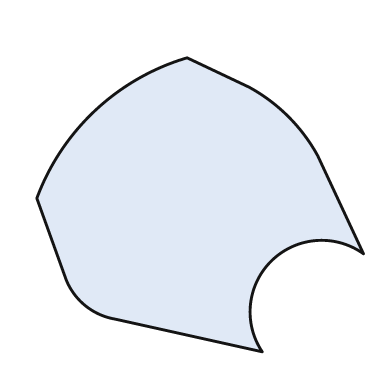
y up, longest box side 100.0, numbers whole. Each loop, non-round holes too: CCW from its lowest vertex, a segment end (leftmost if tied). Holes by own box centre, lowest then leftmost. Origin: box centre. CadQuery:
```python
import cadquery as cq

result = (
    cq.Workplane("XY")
    .moveTo(19.0, -45.0)
    .threePointArc((22.0, -17.0), (50.0, -15.0))
    .lineTo(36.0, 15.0)
    .threePointArc((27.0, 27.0), (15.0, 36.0))
    .lineTo(-4.0, 45.0)
    .threePointArc((-32.0, 29.0), (-50.0, 2.0))
    .lineTo(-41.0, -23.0)
    .threePointArc((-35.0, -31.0), (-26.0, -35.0))
    .close()
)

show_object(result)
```